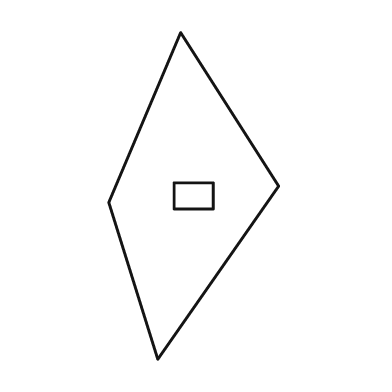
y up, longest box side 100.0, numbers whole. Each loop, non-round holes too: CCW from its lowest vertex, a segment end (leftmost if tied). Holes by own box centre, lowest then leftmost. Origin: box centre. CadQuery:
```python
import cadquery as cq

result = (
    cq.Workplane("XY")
    .moveTo(-11.0, -50.0)
    .lineTo(26.0, 3.0)
    .lineTo(-4.0, 50.0)
    .lineTo(-26.0, -2.0)
    .close()
    .moveTo(-6.0, -4.0)
    .lineTo(6.0, -4.0)
    .lineTo(6.0, 4.0)
    .lineTo(-6.0, 4.0)
    .close()
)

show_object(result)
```